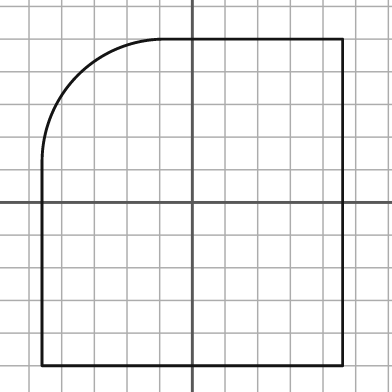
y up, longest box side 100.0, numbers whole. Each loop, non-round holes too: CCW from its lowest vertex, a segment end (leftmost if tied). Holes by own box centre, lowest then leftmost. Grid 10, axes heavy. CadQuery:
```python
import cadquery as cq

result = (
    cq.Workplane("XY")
    .moveTo(-46.0, -50.0)
    .lineTo(46.0, -50.0)
    .lineTo(46.0, 50.0)
    .lineTo(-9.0, 50.0)
    .threePointArc((-35.0, 39.0), (-46.0, 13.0))
    .close()
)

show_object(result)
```